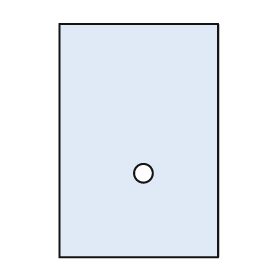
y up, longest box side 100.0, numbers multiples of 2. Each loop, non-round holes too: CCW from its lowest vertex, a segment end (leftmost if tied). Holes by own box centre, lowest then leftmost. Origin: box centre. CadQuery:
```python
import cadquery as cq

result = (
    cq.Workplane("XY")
    .moveTo(-34.0, -50.0)
    .lineTo(34.0, -50.0)
    .lineTo(34.0, 50.0)
    .lineTo(-34.0, 50.0)
    .close()
    .moveTo(2.0, -14.0)
    .circle(4.0)
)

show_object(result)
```